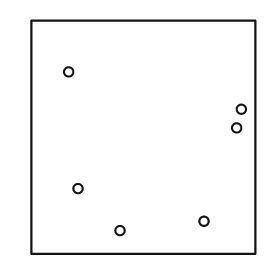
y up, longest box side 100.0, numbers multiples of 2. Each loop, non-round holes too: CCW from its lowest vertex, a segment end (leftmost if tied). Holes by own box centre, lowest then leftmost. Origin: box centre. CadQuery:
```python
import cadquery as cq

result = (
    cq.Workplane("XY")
    .moveTo(-48.0, -50.0)
    .lineTo(48.0, -50.0)
    .lineTo(48.0, 50.0)
    .lineTo(-48.0, 50.0)
    .close()
    .moveTo(-10.0, -40.0)
    .circle(2.0)
    .moveTo(26.0, -36.0)
    .circle(2.0)
    .moveTo(-28.0, -22.0)
    .circle(2.0)
    .moveTo(40.0, 4.0)
    .circle(2.0)
    .moveTo(42.0, 12.0)
    .circle(2.0)
    .moveTo(-32.0, 28.0)
    .circle(2.0)
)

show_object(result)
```